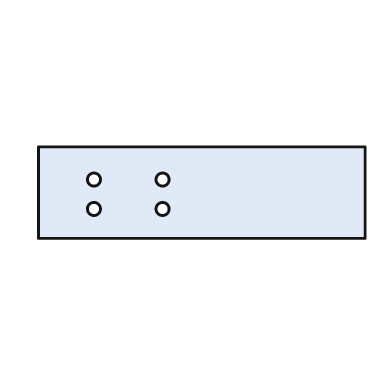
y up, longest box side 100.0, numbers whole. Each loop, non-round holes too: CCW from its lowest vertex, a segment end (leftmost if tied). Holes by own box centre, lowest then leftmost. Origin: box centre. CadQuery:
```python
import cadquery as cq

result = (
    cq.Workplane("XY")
    .moveTo(-50.0, -14.0)
    .lineTo(50.0, -14.0)
    .lineTo(50.0, 14.0)
    .lineTo(-50.0, 14.0)
    .close()
    .moveTo(-33.0, -5.0)
    .circle(2.0)
    .moveTo(-12.0, -5.0)
    .circle(2.0)
    .moveTo(-33.0, 4.0)
    .circle(2.0)
    .moveTo(-12.0, 4.0)
    .circle(2.0)
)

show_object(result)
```